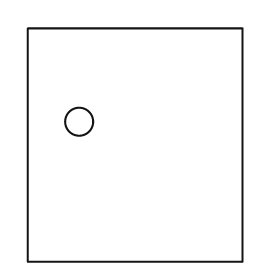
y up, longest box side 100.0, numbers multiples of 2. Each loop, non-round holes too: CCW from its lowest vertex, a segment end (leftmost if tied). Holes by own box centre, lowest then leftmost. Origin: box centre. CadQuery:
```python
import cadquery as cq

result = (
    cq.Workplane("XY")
    .moveTo(-46.0, -50.0)
    .lineTo(46.0, -50.0)
    .lineTo(46.0, 50.0)
    .lineTo(-46.0, 50.0)
    .close()
    .moveTo(-24.0, 10.0)
    .circle(6.0)
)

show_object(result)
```